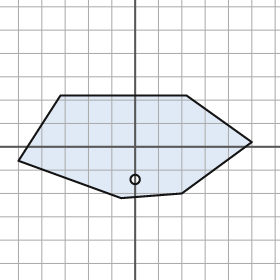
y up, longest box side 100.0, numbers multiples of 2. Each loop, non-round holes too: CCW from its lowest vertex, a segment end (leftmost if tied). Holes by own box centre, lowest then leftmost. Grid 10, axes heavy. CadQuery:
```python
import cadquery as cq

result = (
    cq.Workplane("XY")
    .moveTo(-6.0, -22.0)
    .lineTo(20.0, -20.0)
    .lineTo(50.0, 2.0)
    .lineTo(22.0, 22.0)
    .lineTo(-32.0, 22.0)
    .lineTo(-50.0, -6.0)
    .close()
    .moveTo(0.0, -14.0)
    .circle(2.0)
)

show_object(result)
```